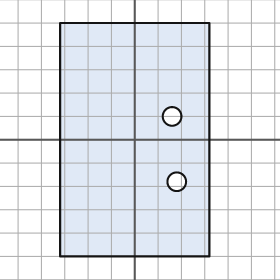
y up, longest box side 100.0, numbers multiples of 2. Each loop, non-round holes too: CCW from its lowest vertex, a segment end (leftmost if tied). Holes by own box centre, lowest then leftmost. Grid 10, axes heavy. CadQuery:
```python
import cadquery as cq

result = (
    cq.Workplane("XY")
    .moveTo(-32.0, -50.0)
    .lineTo(32.0, -50.0)
    .lineTo(32.0, 50.0)
    .lineTo(-32.0, 50.0)
    .close()
    .moveTo(18.0, -18.0)
    .circle(4.0)
    .moveTo(16.0, 10.0)
    .circle(4.0)
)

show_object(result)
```